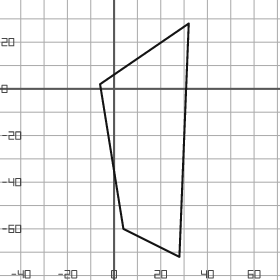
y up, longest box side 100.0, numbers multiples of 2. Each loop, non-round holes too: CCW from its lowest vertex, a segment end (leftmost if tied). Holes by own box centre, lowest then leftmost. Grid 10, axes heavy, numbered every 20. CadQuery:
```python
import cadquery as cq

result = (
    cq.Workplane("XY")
    .moveTo(28.0, -72.0)
    .lineTo(32.0, 28.0)
    .lineTo(-6.0, 2.0)
    .lineTo(4.0, -60.0)
    .close()
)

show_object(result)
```